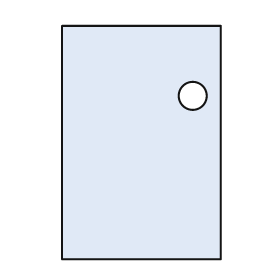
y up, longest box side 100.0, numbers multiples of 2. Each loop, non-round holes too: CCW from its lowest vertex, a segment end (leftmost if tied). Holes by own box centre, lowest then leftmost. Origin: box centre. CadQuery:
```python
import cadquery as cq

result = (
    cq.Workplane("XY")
    .moveTo(-34.0, -50.0)
    .lineTo(34.0, -50.0)
    .lineTo(34.0, 50.0)
    .lineTo(-34.0, 50.0)
    .close()
    .moveTo(22.0, 20.0)
    .circle(6.0)
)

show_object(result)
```